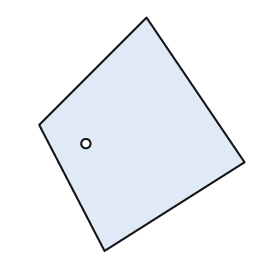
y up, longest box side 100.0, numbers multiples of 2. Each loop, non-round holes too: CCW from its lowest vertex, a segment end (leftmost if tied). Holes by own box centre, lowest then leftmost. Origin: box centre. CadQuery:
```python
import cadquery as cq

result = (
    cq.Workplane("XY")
    .moveTo(-16.0, -50.0)
    .lineTo(44.0, -12.0)
    .lineTo(2.0, 50.0)
    .lineTo(-44.0, 4.0)
    .close()
    .moveTo(-24.0, -4.0)
    .circle(2.0)
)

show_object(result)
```